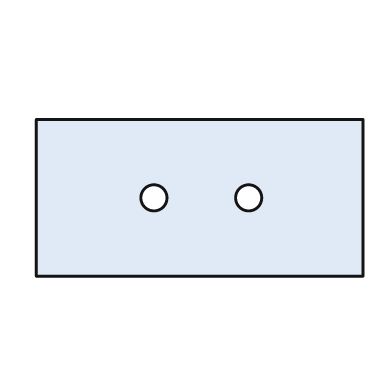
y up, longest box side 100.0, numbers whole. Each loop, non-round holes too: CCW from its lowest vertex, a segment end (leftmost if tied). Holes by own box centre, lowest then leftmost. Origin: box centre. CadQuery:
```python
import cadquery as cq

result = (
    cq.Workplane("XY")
    .moveTo(-50.0, -24.0)
    .lineTo(50.0, -24.0)
    .lineTo(50.0, 24.0)
    .lineTo(-50.0, 24.0)
    .close()
    .moveTo(-14.0, 0.0)
    .circle(4.0)
    .moveTo(15.0, 0.0)
    .circle(4.0)
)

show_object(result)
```